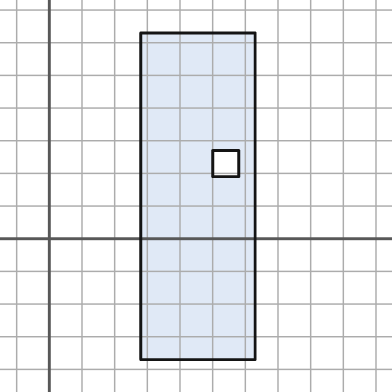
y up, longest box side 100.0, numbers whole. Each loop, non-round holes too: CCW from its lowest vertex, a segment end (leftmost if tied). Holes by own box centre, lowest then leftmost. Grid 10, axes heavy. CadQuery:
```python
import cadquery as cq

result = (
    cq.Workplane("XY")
    .moveTo(28.0, -37.0)
    .lineTo(63.0, -37.0)
    .lineTo(63.0, 63.0)
    .lineTo(28.0, 63.0)
    .close()
    .moveTo(50.0, 19.0)
    .lineTo(58.0, 19.0)
    .lineTo(58.0, 27.0)
    .lineTo(50.0, 27.0)
    .close()
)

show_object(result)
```